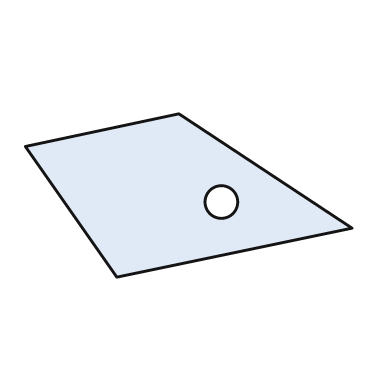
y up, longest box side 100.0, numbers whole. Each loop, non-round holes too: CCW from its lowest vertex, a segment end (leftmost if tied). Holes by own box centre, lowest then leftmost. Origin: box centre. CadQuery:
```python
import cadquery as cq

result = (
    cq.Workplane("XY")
    .moveTo(-22.0, -25.0)
    .lineTo(50.0, -10.0)
    .lineTo(-3.0, 25.0)
    .lineTo(-50.0, 15.0)
    .close()
    .moveTo(10.0, -2.0)
    .circle(5.0)
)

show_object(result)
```